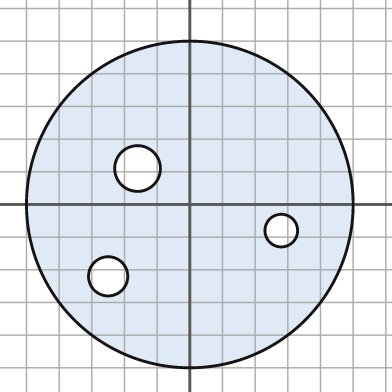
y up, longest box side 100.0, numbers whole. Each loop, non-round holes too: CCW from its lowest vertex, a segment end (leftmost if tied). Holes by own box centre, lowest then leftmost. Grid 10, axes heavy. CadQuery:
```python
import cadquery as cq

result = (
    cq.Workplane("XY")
    .moveTo(0.0, 0.0)
    .circle(50.0)
    .moveTo(-25.0, -22.0)
    .circle(6.0)
    .moveTo(28.0, -8.0)
    .circle(5.0)
    .moveTo(-16.0, 11.0)
    .circle(7.0)
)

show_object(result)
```